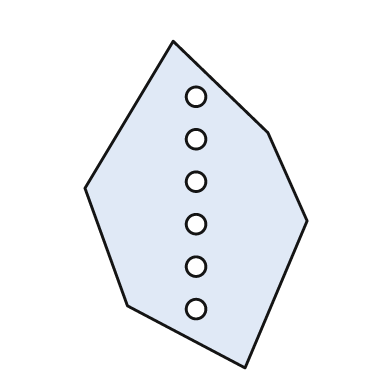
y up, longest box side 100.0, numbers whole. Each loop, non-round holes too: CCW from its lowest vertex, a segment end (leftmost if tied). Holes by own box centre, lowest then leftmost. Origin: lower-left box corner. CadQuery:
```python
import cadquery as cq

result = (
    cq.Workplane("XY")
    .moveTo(49.0, 0.0)
    .lineTo(68.0, 45.0)
    .lineTo(56.0, 72.0)
    .lineTo(27.0, 100.0)
    .lineTo(0.0, 55.0)
    .lineTo(13.0, 19.0)
    .close()
    .moveTo(34.0, 18.0)
    .circle(3.0)
    .moveTo(34.0, 31.0)
    .circle(3.0)
    .moveTo(34.0, 44.0)
    .circle(3.0)
    .moveTo(34.0, 57.0)
    .circle(3.0)
    .moveTo(34.0, 70.0)
    .circle(3.0)
    .moveTo(34.0, 83.0)
    .circle(3.0)
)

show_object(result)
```